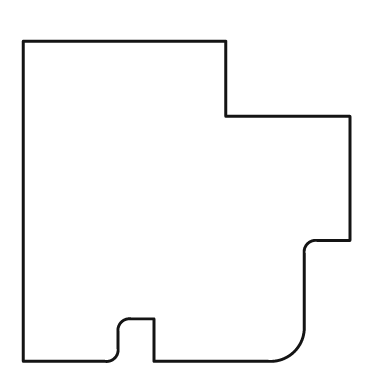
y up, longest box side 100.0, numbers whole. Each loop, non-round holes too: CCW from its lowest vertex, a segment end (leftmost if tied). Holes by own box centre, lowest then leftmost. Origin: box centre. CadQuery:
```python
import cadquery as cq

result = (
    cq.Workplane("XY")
    .moveTo(-50.0, -49.0)
    .lineTo(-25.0, -49.0)
    .threePointArc((-22.0, -48.0), (-21.0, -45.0))
    .lineTo(-21.0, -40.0)
    .threePointArc((-20.0, -37.0), (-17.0, -36.0))
    .lineTo(-10.0, -36.0)
    .lineTo(-10.0, -49.0)
    .lineTo(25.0, -49.0)
    .threePointArc((33.0, -46.0), (36.0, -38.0))
    .lineTo(36.0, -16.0)
    .threePointArc((37.0, -13.0), (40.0, -12.0))
    .lineTo(50.0, -12.0)
    .lineTo(50.0, 26.0)
    .lineTo(12.0, 26.0)
    .lineTo(12.0, 49.0)
    .lineTo(-50.0, 49.0)
    .close()
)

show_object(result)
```